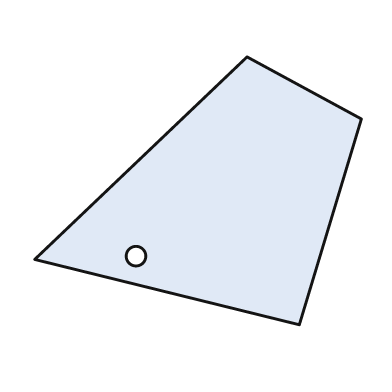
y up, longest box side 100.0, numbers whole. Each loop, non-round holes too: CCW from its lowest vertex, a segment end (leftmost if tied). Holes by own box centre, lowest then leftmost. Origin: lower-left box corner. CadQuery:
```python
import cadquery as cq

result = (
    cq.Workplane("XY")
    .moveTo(81.0, 0.0)
    .lineTo(100.0, 63.0)
    .lineTo(65.0, 82.0)
    .lineTo(0.0, 20.0)
    .close()
    .moveTo(31.0, 21.0)
    .circle(3.0)
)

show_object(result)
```